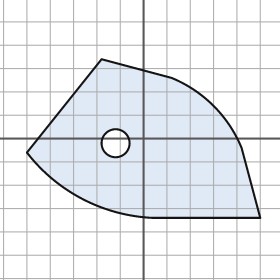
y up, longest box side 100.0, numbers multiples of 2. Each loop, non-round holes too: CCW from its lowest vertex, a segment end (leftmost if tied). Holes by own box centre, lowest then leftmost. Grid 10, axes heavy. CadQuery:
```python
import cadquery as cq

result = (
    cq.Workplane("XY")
    .moveTo(4.0, -34.0)
    .lineTo(50.0, -34.0)
    .lineTo(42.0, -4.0)
    .threePointArc((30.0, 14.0), (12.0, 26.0))
    .lineTo(-18.0, 34.0)
    .lineTo(-50.0, -6.0)
    .threePointArc((-26.0, -26.0), (4.0, -34.0))
    .close()
    .moveTo(-12.0, -2.0)
    .circle(6.0)
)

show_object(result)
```